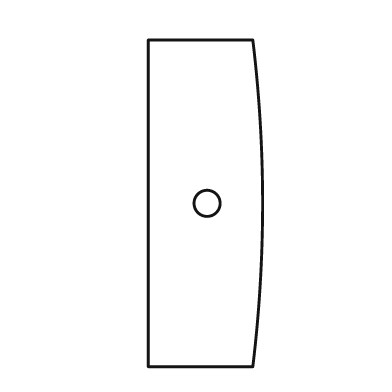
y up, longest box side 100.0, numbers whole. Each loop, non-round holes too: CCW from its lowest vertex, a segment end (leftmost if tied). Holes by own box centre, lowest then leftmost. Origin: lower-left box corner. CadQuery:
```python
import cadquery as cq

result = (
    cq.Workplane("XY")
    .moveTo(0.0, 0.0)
    .lineTo(32.0, 0.0)
    .threePointArc((35.0, 50.0), (32.0, 100.0))
    .lineTo(0.0, 100.0)
    .close()
    .moveTo(18.0, 50.0)
    .circle(4.0)
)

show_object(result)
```